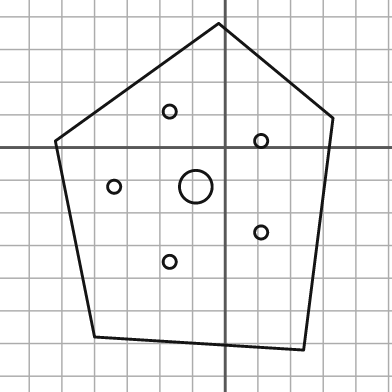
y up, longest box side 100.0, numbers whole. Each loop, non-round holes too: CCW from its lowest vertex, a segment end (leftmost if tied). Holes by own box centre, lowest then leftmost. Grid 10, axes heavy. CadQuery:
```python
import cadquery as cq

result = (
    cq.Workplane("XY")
    .moveTo(24.0, -62.0)
    .lineTo(33.0, 9.0)
    .lineTo(-2.0, 38.0)
    .lineTo(-52.0, 2.0)
    .lineTo(-40.0, -58.0)
    .close()
    .moveTo(-17.0, -35.0)
    .circle(2.0)
    .moveTo(11.0, -26.0)
    .circle(2.0)
    .moveTo(-34.0, -12.0)
    .circle(2.0)
    .moveTo(-9.0, -12.0)
    .circle(5.0)
    .moveTo(11.0, 2.0)
    .circle(2.0)
    .moveTo(-17.0, 11.0)
    .circle(2.0)
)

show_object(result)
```